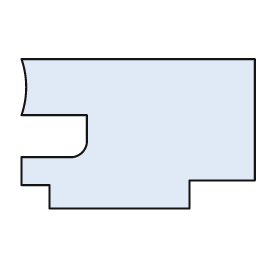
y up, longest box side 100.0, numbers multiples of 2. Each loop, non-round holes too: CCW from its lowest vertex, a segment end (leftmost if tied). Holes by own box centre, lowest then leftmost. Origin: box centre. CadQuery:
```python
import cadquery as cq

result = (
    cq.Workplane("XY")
    .moveTo(-38.0, -32.0)
    .lineTo(22.0, -32.0)
    .lineTo(22.0, -20.0)
    .lineTo(50.0, -20.0)
    .lineTo(50.0, 32.0)
    .lineTo(-50.0, 32.0)
    .threePointArc((-48.0, 20.0), (-50.0, 8.0))
    .lineTo(-22.0, 8.0)
    .lineTo(-22.0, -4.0)
    .threePointArc((-24.0, -8.0), (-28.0, -10.0))
    .lineTo(-50.0, -10.0)
    .lineTo(-50.0, -22.0)
    .lineTo(-38.0, -22.0)
    .close()
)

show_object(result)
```